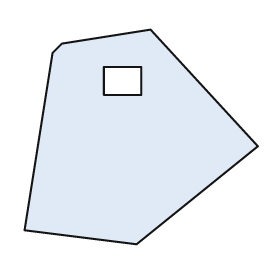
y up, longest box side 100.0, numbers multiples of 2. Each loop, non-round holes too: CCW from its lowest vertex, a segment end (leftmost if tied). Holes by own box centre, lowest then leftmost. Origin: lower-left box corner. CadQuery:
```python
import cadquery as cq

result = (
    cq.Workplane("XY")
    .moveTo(48.0, 0.0)
    .lineTo(100.0, 42.0)
    .lineTo(54.0, 92.0)
    .lineTo(16.0, 86.0)
    .lineTo(12.0, 82.0)
    .lineTo(0.0, 6.0)
    .close()
    .moveTo(34.0, 64.0)
    .lineTo(50.0, 64.0)
    .lineTo(50.0, 76.0)
    .lineTo(34.0, 76.0)
    .close()
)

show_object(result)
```